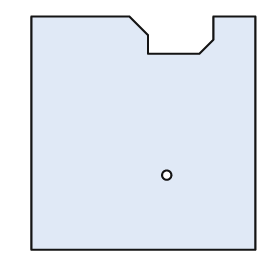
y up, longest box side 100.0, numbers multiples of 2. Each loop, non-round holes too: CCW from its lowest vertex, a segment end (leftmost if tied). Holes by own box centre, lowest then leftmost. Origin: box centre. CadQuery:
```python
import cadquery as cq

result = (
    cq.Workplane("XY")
    .moveTo(-48.0, -50.0)
    .lineTo(48.0, -50.0)
    .lineTo(48.0, 50.0)
    .lineTo(30.0, 50.0)
    .lineTo(30.0, 40.0)
    .lineTo(24.0, 34.0)
    .lineTo(2.0, 34.0)
    .lineTo(2.0, 42.0)
    .lineTo(-6.0, 50.0)
    .lineTo(-48.0, 50.0)
    .close()
    .moveTo(10.0, -18.0)
    .circle(2.0)
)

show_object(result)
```